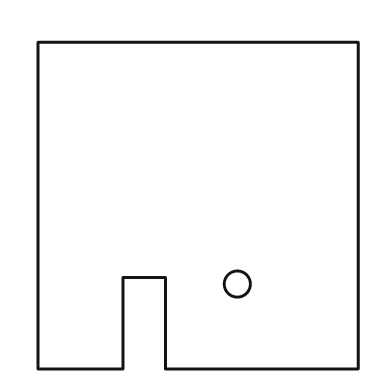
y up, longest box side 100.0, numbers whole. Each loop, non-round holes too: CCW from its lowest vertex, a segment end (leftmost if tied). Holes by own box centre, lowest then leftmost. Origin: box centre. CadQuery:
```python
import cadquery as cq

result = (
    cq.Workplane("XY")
    .moveTo(-49.0, -50.0)
    .lineTo(-23.0, -50.0)
    .lineTo(-23.0, -22.0)
    .lineTo(-10.0, -22.0)
    .lineTo(-10.0, -50.0)
    .lineTo(49.0, -50.0)
    .lineTo(49.0, 50.0)
    .lineTo(-49.0, 50.0)
    .close()
    .moveTo(12.0, -24.0)
    .circle(4.0)
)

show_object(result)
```